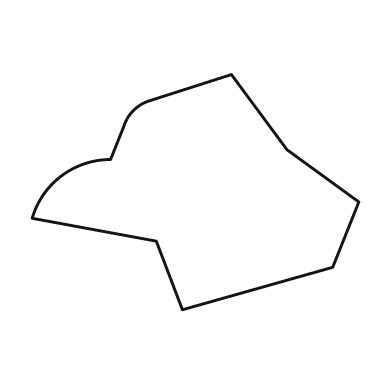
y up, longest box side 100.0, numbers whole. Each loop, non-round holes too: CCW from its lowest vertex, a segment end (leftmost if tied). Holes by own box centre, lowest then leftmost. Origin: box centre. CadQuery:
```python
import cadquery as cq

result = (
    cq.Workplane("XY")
    .moveTo(-4.0, -36.0)
    .lineTo(42.0, -23.0)
    .lineTo(50.0, -3.0)
    .lineTo(28.0, 13.0)
    .lineTo(11.0, 36.0)
    .lineTo(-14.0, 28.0)
    .threePointArc((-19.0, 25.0), (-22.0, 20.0))
    .lineTo(-26.0, 10.0)
    .threePointArc((-41.0, 5.0), (-50.0, -8.0))
    .lineTo(-12.0, -15.0)
    .close()
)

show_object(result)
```